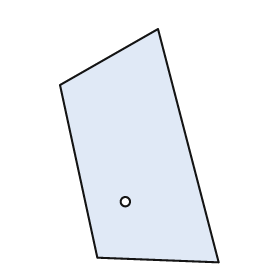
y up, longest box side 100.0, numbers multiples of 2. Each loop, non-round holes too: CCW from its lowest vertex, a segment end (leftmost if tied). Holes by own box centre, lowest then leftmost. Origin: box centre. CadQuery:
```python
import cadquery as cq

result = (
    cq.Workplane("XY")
    .moveTo(34.0, -50.0)
    .lineTo(8.0, 50.0)
    .lineTo(-34.0, 26.0)
    .lineTo(-18.0, -48.0)
    .close()
    .moveTo(-6.0, -24.0)
    .circle(2.0)
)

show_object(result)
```